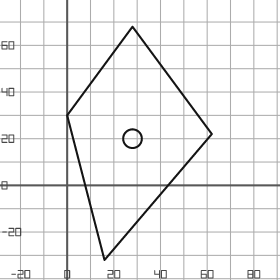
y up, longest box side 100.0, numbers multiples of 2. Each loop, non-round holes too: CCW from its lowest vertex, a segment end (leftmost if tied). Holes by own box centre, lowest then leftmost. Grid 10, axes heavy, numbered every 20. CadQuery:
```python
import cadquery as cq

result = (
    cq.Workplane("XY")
    .moveTo(16.0, -32.0)
    .lineTo(62.0, 22.0)
    .lineTo(28.0, 68.0)
    .lineTo(0.0, 30.0)
    .close()
    .moveTo(28.0, 20.0)
    .circle(4.0)
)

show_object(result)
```